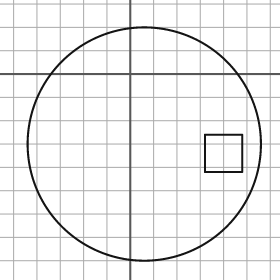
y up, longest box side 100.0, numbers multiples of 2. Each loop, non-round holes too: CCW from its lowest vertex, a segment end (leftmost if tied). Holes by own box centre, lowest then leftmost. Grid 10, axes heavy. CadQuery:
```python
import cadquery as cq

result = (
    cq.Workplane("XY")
    .moveTo(6.0, -30.0)
    .circle(50.0)
    .moveTo(32.0, -42.0)
    .lineTo(48.0, -42.0)
    .lineTo(48.0, -26.0)
    .lineTo(32.0, -26.0)
    .close()
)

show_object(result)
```